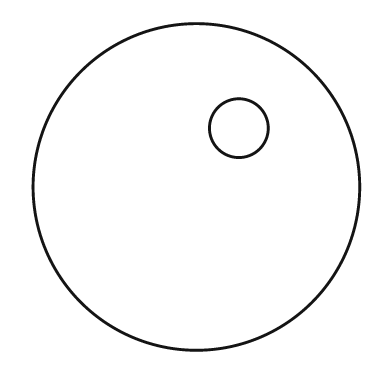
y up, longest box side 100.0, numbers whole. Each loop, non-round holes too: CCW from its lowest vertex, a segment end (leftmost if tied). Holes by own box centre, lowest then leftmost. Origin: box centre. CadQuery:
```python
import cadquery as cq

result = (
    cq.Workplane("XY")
    .moveTo(0.0, 0.0)
    .circle(50.0)
    .moveTo(13.0, 18.0)
    .circle(9.0)
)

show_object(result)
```